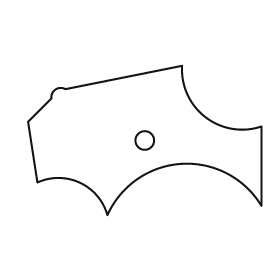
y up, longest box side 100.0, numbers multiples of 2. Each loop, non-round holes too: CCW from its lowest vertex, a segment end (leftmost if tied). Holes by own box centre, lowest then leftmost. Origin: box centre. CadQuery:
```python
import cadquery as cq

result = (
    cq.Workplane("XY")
    .moveTo(-16.0, -32.0)
    .threePointArc((16.0, -10.0), (50.0, -28.0))
    .lineTo(50.0, 6.0)
    .threePointArc((26.0, 10.0), (16.0, 32.0))
    .lineTo(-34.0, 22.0)
    .threePointArc((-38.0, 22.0), (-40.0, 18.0))
    .lineTo(-50.0, 8.0)
    .lineTo(-46.0, -18.0)
    .threePointArc((-28.0, -18.0), (-16.0, -32.0))
    .close()
    .moveTo(0.0, 0.0)
    .circle(4.0)
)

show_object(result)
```